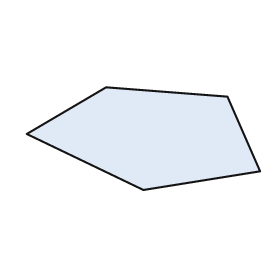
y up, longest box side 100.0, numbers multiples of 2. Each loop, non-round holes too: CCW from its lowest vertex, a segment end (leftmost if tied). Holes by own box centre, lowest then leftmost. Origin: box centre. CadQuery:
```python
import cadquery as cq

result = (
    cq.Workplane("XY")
    .moveTo(0.0, -22.0)
    .lineTo(50.0, -14.0)
    .lineTo(36.0, 18.0)
    .lineTo(-16.0, 22.0)
    .lineTo(-50.0, 2.0)
    .close()
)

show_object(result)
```